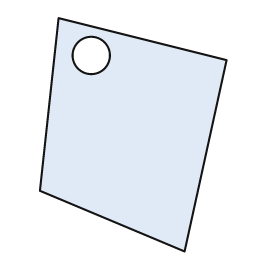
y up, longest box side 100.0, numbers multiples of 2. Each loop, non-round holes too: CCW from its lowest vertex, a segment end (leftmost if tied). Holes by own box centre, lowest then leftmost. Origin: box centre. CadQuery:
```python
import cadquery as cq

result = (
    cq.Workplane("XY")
    .moveTo(22.0, -50.0)
    .lineTo(40.0, 32.0)
    .lineTo(-32.0, 50.0)
    .lineTo(-40.0, -24.0)
    .close()
    .moveTo(-18.0, 34.0)
    .circle(8.0)
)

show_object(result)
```